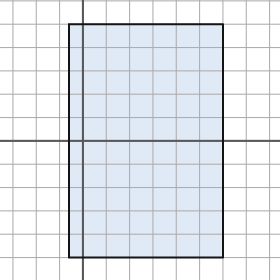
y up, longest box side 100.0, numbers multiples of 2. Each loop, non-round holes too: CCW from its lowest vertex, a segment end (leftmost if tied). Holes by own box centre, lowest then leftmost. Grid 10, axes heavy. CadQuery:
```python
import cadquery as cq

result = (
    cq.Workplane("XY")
    .moveTo(-6.0, -50.0)
    .lineTo(60.0, -50.0)
    .lineTo(60.0, 50.0)
    .lineTo(-6.0, 50.0)
    .close()
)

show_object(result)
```